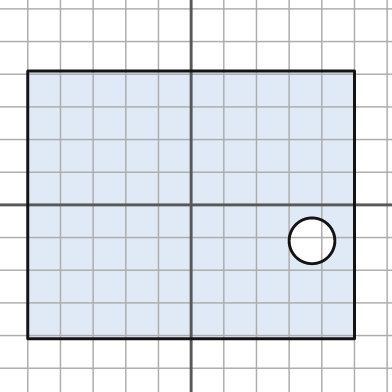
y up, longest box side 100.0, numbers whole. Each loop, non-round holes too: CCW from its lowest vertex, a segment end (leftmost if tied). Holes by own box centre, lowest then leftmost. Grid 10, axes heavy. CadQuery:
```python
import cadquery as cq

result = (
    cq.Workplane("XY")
    .moveTo(-50.0, -41.0)
    .lineTo(50.0, -41.0)
    .lineTo(50.0, 41.0)
    .lineTo(-50.0, 41.0)
    .close()
    .moveTo(37.0, -11.0)
    .circle(7.0)
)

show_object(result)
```